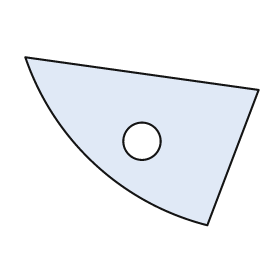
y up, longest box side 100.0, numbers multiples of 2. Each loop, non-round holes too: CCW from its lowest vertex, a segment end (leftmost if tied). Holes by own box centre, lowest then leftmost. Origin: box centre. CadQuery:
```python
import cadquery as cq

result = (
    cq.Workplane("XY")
    .moveTo(28.0, -36.0)
    .lineTo(50.0, 22.0)
    .lineTo(-50.0, 36.0)
    .threePointArc((-20.0, -10.0), (28.0, -36.0))
    .close()
    .moveTo(0.0, 0.0)
    .circle(8.0)
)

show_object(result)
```